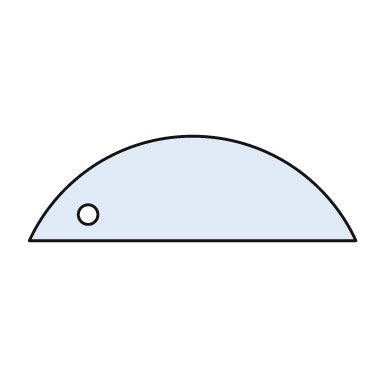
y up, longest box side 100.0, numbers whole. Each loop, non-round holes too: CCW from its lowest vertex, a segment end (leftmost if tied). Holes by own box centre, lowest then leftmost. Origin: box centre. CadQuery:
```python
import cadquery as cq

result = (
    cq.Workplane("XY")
    .moveTo(-50.0, -16.0)
    .lineTo(50.0, -16.0)
    .threePointArc((0.0, 16.0), (-50.0, -16.0))
    .close()
    .moveTo(-32.0, -8.0)
    .circle(3.0)
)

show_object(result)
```